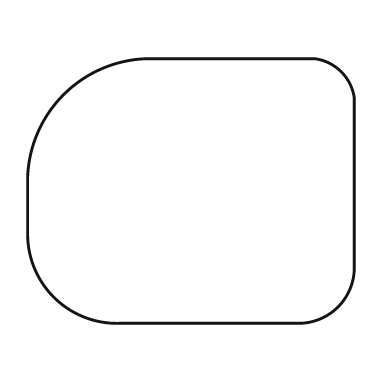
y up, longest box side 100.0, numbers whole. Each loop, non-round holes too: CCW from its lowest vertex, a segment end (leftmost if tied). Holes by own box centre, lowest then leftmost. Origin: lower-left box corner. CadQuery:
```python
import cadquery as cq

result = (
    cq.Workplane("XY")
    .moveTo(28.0, 0.0)
    .lineTo(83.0, 0.0)
    .threePointArc((95.0, 5.0), (100.0, 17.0))
    .lineTo(100.0, 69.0)
    .threePointArc((96.0, 77.0), (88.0, 81.0))
    .lineTo(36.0, 81.0)
    .threePointArc((11.0, 70.0), (0.0, 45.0))
    .lineTo(0.0, 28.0)
    .threePointArc((8.0, 8.0), (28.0, 0.0))
    .close()
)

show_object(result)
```